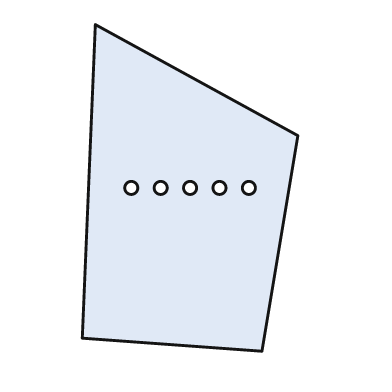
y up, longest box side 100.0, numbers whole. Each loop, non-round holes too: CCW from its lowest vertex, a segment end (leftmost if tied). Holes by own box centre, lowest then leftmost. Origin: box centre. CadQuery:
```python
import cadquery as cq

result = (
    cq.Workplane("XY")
    .moveTo(22.0, -50.0)
    .lineTo(33.0, 16.0)
    .lineTo(-29.0, 50.0)
    .lineTo(-33.0, -46.0)
    .close()
    .moveTo(-18.0, 0.0)
    .circle(2.0)
    .moveTo(-9.0, 0.0)
    .circle(2.0)
    .moveTo(0.0, 0.0)
    .circle(2.0)
    .moveTo(9.0, 0.0)
    .circle(2.0)
    .moveTo(18.0, 0.0)
    .circle(2.0)
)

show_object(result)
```